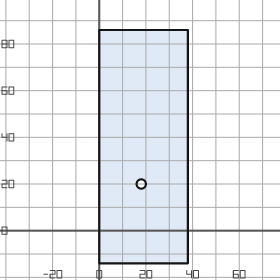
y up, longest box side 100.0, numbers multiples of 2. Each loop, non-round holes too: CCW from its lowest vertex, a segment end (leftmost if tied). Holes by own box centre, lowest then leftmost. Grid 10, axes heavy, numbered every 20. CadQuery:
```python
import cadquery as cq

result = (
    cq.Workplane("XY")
    .moveTo(0.0, -14.0)
    .lineTo(38.0, -14.0)
    .lineTo(38.0, 86.0)
    .lineTo(0.0, 86.0)
    .close()
    .moveTo(18.0, 20.0)
    .circle(2.0)
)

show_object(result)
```